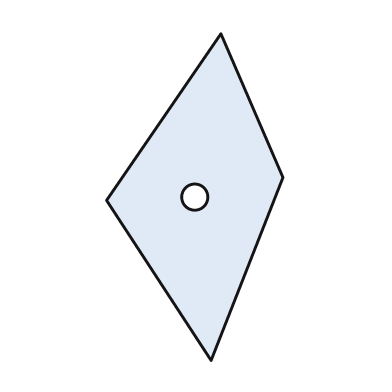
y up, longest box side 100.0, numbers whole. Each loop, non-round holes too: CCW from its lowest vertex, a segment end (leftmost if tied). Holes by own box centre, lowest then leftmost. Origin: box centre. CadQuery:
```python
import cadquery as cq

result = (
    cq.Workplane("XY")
    .moveTo(5.0, -50.0)
    .lineTo(27.0, 6.0)
    .lineTo(8.0, 50.0)
    .lineTo(-27.0, -1.0)
    .close()
    .moveTo(0.0, 0.0)
    .circle(4.0)
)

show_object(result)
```